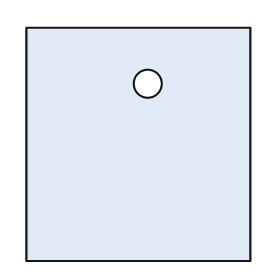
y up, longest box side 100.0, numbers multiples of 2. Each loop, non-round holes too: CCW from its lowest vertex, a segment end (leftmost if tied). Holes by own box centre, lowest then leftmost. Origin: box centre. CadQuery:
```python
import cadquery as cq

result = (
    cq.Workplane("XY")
    .moveTo(-48.0, -50.0)
    .lineTo(48.0, -50.0)
    .lineTo(48.0, 50.0)
    .lineTo(-48.0, 50.0)
    .close()
    .moveTo(4.0, 26.0)
    .circle(6.0)
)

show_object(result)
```